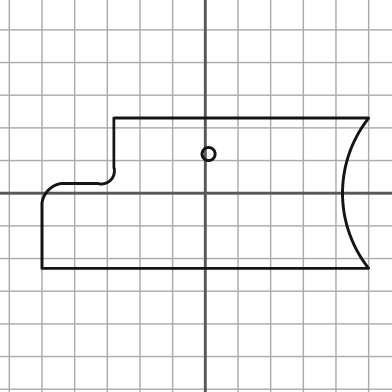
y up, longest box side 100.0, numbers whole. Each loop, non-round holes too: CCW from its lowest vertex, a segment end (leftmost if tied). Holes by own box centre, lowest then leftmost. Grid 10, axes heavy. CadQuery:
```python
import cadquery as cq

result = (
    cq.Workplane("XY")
    .moveTo(-50.0, -23.0)
    .lineTo(50.0, -23.0)
    .threePointArc((42.0, 0.0), (50.0, 23.0))
    .lineTo(-28.0, 23.0)
    .lineTo(-28.0, 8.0)
    .threePointArc((-29.0, 4.0), (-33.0, 3.0))
    .lineTo(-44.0, 3.0)
    .threePointArc((-48.0, 1.0), (-50.0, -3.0))
    .close()
    .moveTo(1.0, 12.0)
    .circle(2.0)
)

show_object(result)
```